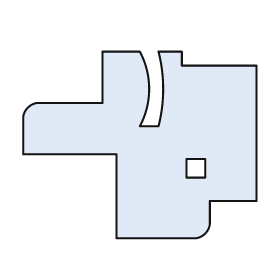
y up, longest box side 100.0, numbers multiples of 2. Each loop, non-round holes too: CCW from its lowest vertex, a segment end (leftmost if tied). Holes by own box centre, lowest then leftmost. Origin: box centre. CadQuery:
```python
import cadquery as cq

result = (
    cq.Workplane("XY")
    .moveTo(-10.0, -40.0)
    .lineTo(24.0, -40.0)
    .threePointArc((28.0, -38.0), (30.0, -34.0))
    .lineTo(30.0, -24.0)
    .lineTo(50.0, -24.0)
    .lineTo(50.0, 34.0)
    .lineTo(18.0, 34.0)
    .lineTo(18.0, 40.0)
    .lineTo(8.0, 40.0)
    .threePointArc((10.0, 24.0), (8.0, 8.0))
    .lineTo(0.0, 8.0)
    .threePointArc((4.0, 24.0), (0.0, 40.0))
    .lineTo(-16.0, 40.0)
    .lineTo(-16.0, 18.0)
    .lineTo(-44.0, 18.0)
    .threePointArc((-48.0, 16.0), (-50.0, 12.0))
    .lineTo(-50.0, -4.0)
    .lineTo(-10.0, -4.0)
    .close()
    .moveTo(20.0, -14.0)
    .lineTo(28.0, -14.0)
    .lineTo(28.0, -6.0)
    .lineTo(20.0, -6.0)
    .close()
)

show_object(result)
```